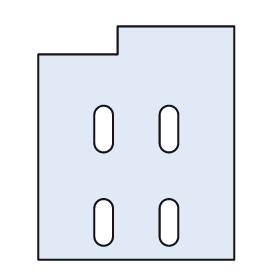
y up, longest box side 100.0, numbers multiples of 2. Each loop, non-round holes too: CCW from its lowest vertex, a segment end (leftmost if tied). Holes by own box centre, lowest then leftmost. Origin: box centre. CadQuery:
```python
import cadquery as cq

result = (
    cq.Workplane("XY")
    .moveTo(-42.0, -50.0)
    .lineTo(42.0, -50.0)
    .lineTo(42.0, 50.0)
    .lineTo(-8.0, 50.0)
    .lineTo(-8.0, 38.0)
    .lineTo(-42.0, 38.0)
    .close()
    .moveTo(-18.0, -40.0)
    .threePointArc((-14.0, -44.0), (-10.0, -40.0))
    .lineTo(-10.0, -28.0)
    .threePointArc((-14.0, -24.0), (-18.0, -28.0))
    .close()
    .moveTo(10.0, -40.0)
    .threePointArc((14.0, -44.0), (18.0, -40.0))
    .lineTo(18.0, -28.0)
    .threePointArc((14.0, -24.0), (10.0, -28.0))
    .close()
    .moveTo(-18.0, 0.0)
    .threePointArc((-14.0, -4.0), (-10.0, 0.0))
    .lineTo(-10.0, 12.0)
    .threePointArc((-14.0, 16.0), (-18.0, 12.0))
    .close()
    .moveTo(10.0, 0.0)
    .threePointArc((14.0, -4.0), (18.0, 0.0))
    .lineTo(18.0, 12.0)
    .threePointArc((14.0, 16.0), (10.0, 12.0))
    .close()
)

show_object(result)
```